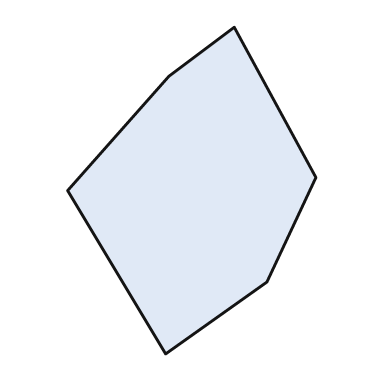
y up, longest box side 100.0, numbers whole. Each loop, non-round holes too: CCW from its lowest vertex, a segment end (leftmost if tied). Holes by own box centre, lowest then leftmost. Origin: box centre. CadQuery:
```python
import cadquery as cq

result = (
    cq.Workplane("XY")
    .moveTo(-8.0, -50.0)
    .lineTo(23.0, -28.0)
    .lineTo(38.0, 4.0)
    .lineTo(13.0, 50.0)
    .lineTo(-7.0, 35.0)
    .lineTo(-38.0, 0.0)
    .close()
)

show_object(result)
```